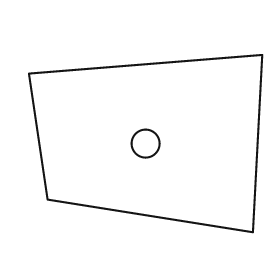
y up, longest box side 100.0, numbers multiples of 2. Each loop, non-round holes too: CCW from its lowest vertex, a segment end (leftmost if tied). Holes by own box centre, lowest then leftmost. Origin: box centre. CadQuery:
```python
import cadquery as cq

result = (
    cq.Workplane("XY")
    .moveTo(46.0, -38.0)
    .lineTo(50.0, 38.0)
    .lineTo(-50.0, 30.0)
    .lineTo(-42.0, -24.0)
    .close()
    .moveTo(0.0, 0.0)
    .circle(6.0)
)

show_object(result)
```